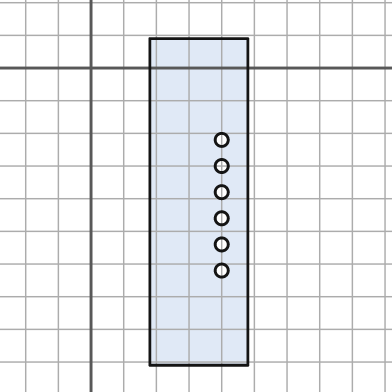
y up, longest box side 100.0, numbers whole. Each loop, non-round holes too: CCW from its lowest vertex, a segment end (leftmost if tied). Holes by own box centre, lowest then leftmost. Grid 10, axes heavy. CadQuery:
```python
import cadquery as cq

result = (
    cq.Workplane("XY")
    .moveTo(18.0, -91.0)
    .lineTo(48.0, -91.0)
    .lineTo(48.0, 9.0)
    .lineTo(18.0, 9.0)
    .close()
    .moveTo(40.0, -62.0)
    .circle(2.0)
    .moveTo(40.0, -54.0)
    .circle(2.0)
    .moveTo(40.0, -46.0)
    .circle(2.0)
    .moveTo(40.0, -38.0)
    .circle(2.0)
    .moveTo(40.0, -30.0)
    .circle(2.0)
    .moveTo(40.0, -22.0)
    .circle(2.0)
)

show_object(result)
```